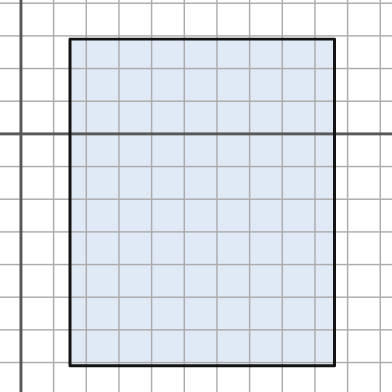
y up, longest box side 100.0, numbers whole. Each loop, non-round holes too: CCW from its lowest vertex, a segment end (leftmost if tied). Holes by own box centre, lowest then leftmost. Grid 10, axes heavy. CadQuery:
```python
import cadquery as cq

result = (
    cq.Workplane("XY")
    .moveTo(15.0, -71.0)
    .lineTo(96.0, -71.0)
    .lineTo(96.0, 29.0)
    .lineTo(15.0, 29.0)
    .close()
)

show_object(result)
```